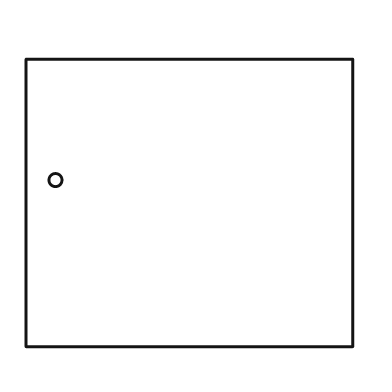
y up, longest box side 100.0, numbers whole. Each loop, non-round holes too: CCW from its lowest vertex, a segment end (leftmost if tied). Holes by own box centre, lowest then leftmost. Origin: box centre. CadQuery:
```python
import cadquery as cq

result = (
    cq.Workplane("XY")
    .moveTo(-50.0, -44.0)
    .lineTo(50.0, -44.0)
    .lineTo(50.0, 44.0)
    .lineTo(-50.0, 44.0)
    .close()
    .moveTo(-41.0, 7.0)
    .circle(2.0)
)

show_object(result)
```